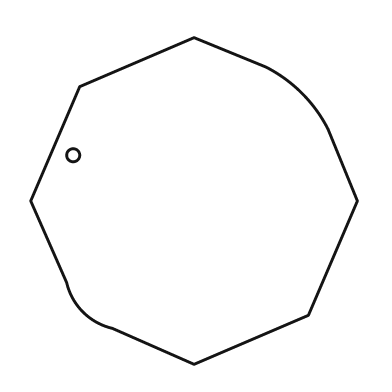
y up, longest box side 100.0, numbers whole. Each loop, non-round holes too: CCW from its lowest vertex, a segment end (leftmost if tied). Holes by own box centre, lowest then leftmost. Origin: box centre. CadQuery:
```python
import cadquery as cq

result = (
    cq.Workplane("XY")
    .moveTo(0.0, -50.0)
    .lineTo(35.0, -35.0)
    .lineTo(50.0, 0.0)
    .lineTo(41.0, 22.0)
    .threePointArc((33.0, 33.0), (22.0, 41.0))
    .lineTo(0.0, 50.0)
    .lineTo(-35.0, 35.0)
    .lineTo(-50.0, 0.0)
    .lineTo(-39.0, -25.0)
    .threePointArc((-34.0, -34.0), (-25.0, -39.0))
    .close()
    .moveTo(-37.0, 14.0)
    .circle(2.0)
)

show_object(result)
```